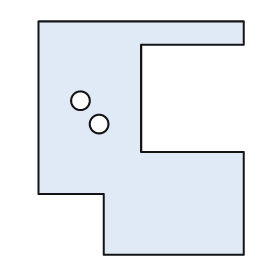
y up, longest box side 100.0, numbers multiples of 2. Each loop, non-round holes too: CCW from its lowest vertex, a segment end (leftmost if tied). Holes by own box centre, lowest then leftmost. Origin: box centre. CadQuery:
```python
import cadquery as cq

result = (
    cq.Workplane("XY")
    .moveTo(-16.0, -50.0)
    .lineTo(44.0, -50.0)
    .lineTo(44.0, -6.0)
    .lineTo(0.0, -6.0)
    .lineTo(0.0, 40.0)
    .lineTo(44.0, 40.0)
    .lineTo(44.0, 50.0)
    .lineTo(-44.0, 50.0)
    .lineTo(-44.0, -24.0)
    .lineTo(-16.0, -24.0)
    .close()
    .moveTo(-18.0, 6.0)
    .circle(4.0)
    .moveTo(-26.0, 16.0)
    .circle(4.0)
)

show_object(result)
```